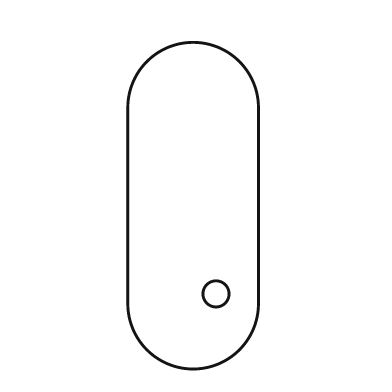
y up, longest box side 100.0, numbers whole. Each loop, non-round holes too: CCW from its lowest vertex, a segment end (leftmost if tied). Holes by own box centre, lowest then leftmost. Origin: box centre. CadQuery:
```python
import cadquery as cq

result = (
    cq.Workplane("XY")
    .moveTo(-20.0, -30.0)
    .threePointArc((0.0, -50.0), (20.0, -30.0))
    .lineTo(20.0, 30.0)
    .threePointArc((0.0, 50.0), (-20.0, 30.0))
    .close()
    .moveTo(7.0, -27.0)
    .circle(4.0)
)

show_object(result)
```